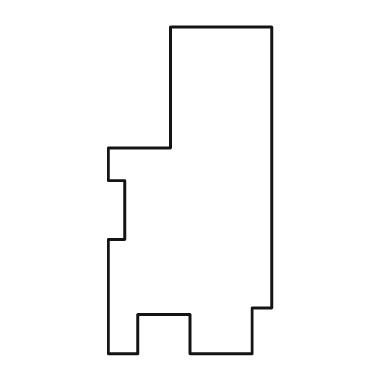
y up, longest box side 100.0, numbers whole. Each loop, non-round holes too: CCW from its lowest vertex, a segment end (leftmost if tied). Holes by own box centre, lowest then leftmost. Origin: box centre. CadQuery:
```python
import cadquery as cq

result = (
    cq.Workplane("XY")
    .moveTo(-25.0, -50.0)
    .lineTo(-16.0, -50.0)
    .lineTo(-16.0, -38.0)
    .lineTo(0.0, -38.0)
    .lineTo(0.0, -50.0)
    .lineTo(19.0, -50.0)
    .lineTo(19.0, -36.0)
    .lineTo(25.0, -36.0)
    .lineTo(25.0, 50.0)
    .lineTo(-6.0, 50.0)
    .lineTo(-6.0, 13.0)
    .lineTo(-25.0, 13.0)
    .lineTo(-25.0, 3.0)
    .lineTo(-20.0, 3.0)
    .lineTo(-20.0, -15.0)
    .lineTo(-25.0, -15.0)
    .close()
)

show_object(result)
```